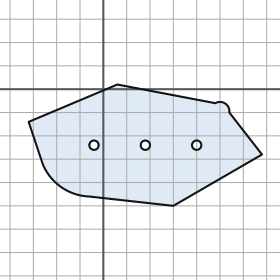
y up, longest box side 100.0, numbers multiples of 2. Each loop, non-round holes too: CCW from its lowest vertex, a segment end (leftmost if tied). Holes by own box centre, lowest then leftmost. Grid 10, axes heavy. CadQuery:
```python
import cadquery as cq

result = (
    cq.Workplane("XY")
    .moveTo(30.0, -50.0)
    .lineTo(68.0, -28.0)
    .lineTo(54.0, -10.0)
    .threePointArc((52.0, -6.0), (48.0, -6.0))
    .lineTo(6.0, 2.0)
    .lineTo(-32.0, -14.0)
    .lineTo(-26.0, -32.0)
    .threePointArc((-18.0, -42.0), (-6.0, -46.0))
    .close()
    .moveTo(-4.0, -24.0)
    .circle(2.0)
    .moveTo(18.0, -24.0)
    .circle(2.0)
    .moveTo(40.0, -24.0)
    .circle(2.0)
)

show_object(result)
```